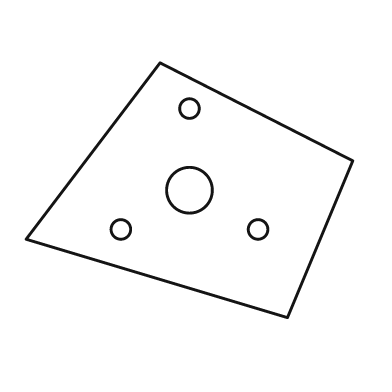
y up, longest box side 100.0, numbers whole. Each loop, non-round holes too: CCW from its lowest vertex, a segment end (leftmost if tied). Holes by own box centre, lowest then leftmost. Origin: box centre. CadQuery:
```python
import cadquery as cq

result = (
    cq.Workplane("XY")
    .moveTo(30.0, -39.0)
    .lineTo(50.0, 9.0)
    .lineTo(-9.0, 39.0)
    .lineTo(-50.0, -15.0)
    .close()
    .moveTo(-21.0, -12.0)
    .circle(3.0)
    .moveTo(21.0, -12.0)
    .circle(3.0)
    .moveTo(0.0, 0.0)
    .circle(7.0)
    .moveTo(0.0, 25.0)
    .circle(3.0)
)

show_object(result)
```